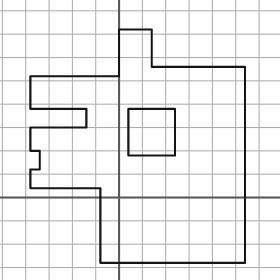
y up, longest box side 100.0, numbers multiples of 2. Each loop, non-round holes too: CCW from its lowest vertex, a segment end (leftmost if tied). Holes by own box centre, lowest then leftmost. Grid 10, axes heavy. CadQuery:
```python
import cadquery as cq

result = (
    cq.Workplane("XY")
    .moveTo(-8.0, -28.0)
    .lineTo(54.0, -28.0)
    .lineTo(54.0, 56.0)
    .lineTo(14.0, 56.0)
    .lineTo(14.0, 72.0)
    .lineTo(0.0, 72.0)
    .lineTo(0.0, 52.0)
    .lineTo(-38.0, 52.0)
    .lineTo(-38.0, 38.0)
    .lineTo(-14.0, 38.0)
    .lineTo(-14.0, 30.0)
    .lineTo(-38.0, 30.0)
    .lineTo(-38.0, 20.0)
    .lineTo(-34.0, 20.0)
    .lineTo(-34.0, 12.0)
    .lineTo(-38.0, 12.0)
    .lineTo(-38.0, 4.0)
    .lineTo(-8.0, 4.0)
    .close()
    .moveTo(4.0, 18.0)
    .lineTo(24.0, 18.0)
    .lineTo(24.0, 38.0)
    .lineTo(4.0, 38.0)
    .close()
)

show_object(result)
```